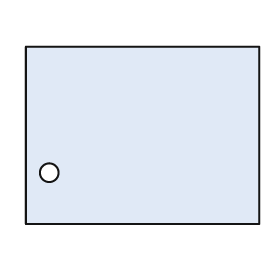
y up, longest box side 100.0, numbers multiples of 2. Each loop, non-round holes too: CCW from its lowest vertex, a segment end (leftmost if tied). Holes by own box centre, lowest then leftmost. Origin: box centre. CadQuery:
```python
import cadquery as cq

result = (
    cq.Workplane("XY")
    .moveTo(-50.0, -38.0)
    .lineTo(50.0, -38.0)
    .lineTo(50.0, 38.0)
    .lineTo(-50.0, 38.0)
    .close()
    .moveTo(-40.0, -16.0)
    .circle(4.0)
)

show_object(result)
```